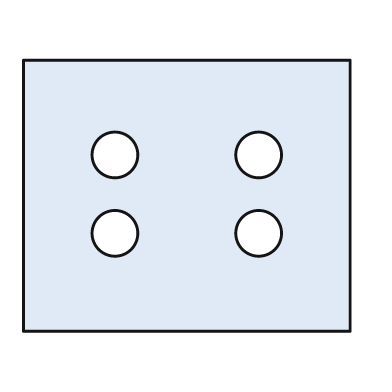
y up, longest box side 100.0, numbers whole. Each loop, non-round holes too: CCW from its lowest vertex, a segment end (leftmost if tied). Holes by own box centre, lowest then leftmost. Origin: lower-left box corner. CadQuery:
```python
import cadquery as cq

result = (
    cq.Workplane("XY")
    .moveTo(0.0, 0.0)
    .lineTo(100.0, 0.0)
    .lineTo(100.0, 83.0)
    .lineTo(0.0, 83.0)
    .close()
    .moveTo(28.0, 30.0)
    .circle(7.0)
    .moveTo(72.0, 30.0)
    .circle(7.0)
    .moveTo(28.0, 54.0)
    .circle(7.0)
    .moveTo(72.0, 54.0)
    .circle(7.0)
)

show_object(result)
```